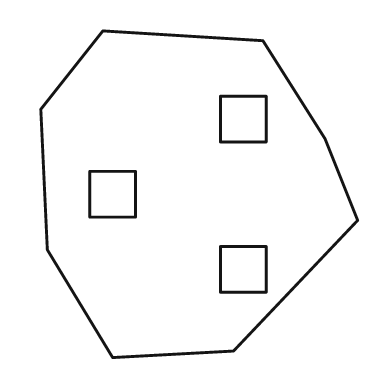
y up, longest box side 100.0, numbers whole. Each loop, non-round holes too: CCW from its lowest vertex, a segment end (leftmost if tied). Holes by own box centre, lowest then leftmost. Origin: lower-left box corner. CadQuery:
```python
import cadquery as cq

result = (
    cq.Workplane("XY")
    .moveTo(22.0, 0.0)
    .lineTo(59.0, 2.0)
    .lineTo(97.0, 42.0)
    .lineTo(87.0, 67.0)
    .lineTo(68.0, 97.0)
    .lineTo(19.0, 100.0)
    .lineTo(0.0, 76.0)
    .lineTo(2.0, 33.0)
    .close()
    .moveTo(55.0, 20.0)
    .lineTo(69.0, 20.0)
    .lineTo(69.0, 34.0)
    .lineTo(55.0, 34.0)
    .close()
    .moveTo(15.0, 43.0)
    .lineTo(29.0, 43.0)
    .lineTo(29.0, 57.0)
    .lineTo(15.0, 57.0)
    .close()
    .moveTo(55.0, 66.0)
    .lineTo(69.0, 66.0)
    .lineTo(69.0, 80.0)
    .lineTo(55.0, 80.0)
    .close()
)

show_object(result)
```